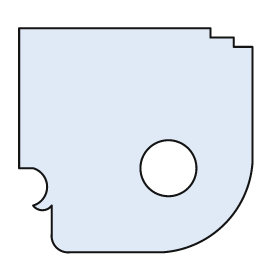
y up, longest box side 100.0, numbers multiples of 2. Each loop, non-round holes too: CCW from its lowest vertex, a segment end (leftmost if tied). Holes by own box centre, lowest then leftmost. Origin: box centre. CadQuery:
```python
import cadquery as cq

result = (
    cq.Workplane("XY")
    .moveTo(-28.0, -48.0)
    .lineTo(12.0, -48.0)
    .threePointArc((38.0, -36.0), (50.0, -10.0))
    .lineTo(50.0, 40.0)
    .lineTo(42.0, 40.0)
    .lineTo(42.0, 44.0)
    .lineTo(32.0, 44.0)
    .lineTo(32.0, 48.0)
    .lineTo(-50.0, 48.0)
    .lineTo(-50.0, -12.0)
    .lineTo(-44.0, -12.0)
    .threePointArc((-38.0, -20.0), (-44.0, -28.0))
    .threePointArc((-40.0, -30.0), (-36.0, -28.0))
    .lineTo(-36.0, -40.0)
    .threePointArc((-34.0, -46.0), (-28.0, -48.0))
    .close()
    .moveTo(14.0, -12.0)
    .circle(12.0)
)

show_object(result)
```